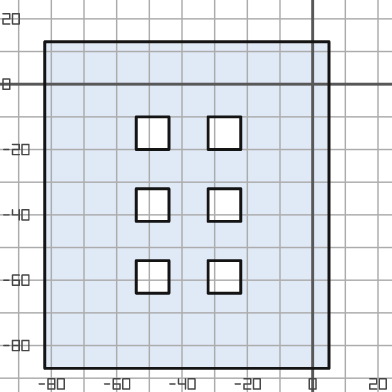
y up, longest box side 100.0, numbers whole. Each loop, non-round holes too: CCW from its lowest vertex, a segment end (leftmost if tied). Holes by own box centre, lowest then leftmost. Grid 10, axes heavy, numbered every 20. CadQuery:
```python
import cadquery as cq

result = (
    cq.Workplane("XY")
    .moveTo(-82.0, -87.0)
    .lineTo(5.0, -87.0)
    .lineTo(5.0, 13.0)
    .lineTo(-82.0, 13.0)
    .close()
    .moveTo(-54.0, -64.0)
    .lineTo(-44.0, -64.0)
    .lineTo(-44.0, -54.0)
    .lineTo(-54.0, -54.0)
    .close()
    .moveTo(-32.0, -64.0)
    .lineTo(-22.0, -64.0)
    .lineTo(-22.0, -54.0)
    .lineTo(-32.0, -54.0)
    .close()
    .moveTo(-54.0, -42.0)
    .lineTo(-44.0, -42.0)
    .lineTo(-44.0, -32.0)
    .lineTo(-54.0, -32.0)
    .close()
    .moveTo(-32.0, -42.0)
    .lineTo(-22.0, -42.0)
    .lineTo(-22.0, -32.0)
    .lineTo(-32.0, -32.0)
    .close()
    .moveTo(-54.0, -20.0)
    .lineTo(-44.0, -20.0)
    .lineTo(-44.0, -10.0)
    .lineTo(-54.0, -10.0)
    .close()
    .moveTo(-32.0, -20.0)
    .lineTo(-22.0, -20.0)
    .lineTo(-22.0, -10.0)
    .lineTo(-32.0, -10.0)
    .close()
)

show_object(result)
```